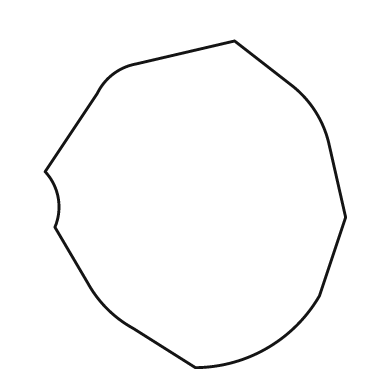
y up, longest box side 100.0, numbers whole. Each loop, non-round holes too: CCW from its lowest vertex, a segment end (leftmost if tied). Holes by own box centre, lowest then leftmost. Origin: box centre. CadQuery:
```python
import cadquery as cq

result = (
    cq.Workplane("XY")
    .moveTo(0.0, -50.0)
    .threePointArc((22.0, -44.0), (38.0, -28.0))
    .lineTo(46.0, -4.0)
    .lineTo(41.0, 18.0)
    .threePointArc((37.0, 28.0), (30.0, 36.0))
    .lineTo(12.0, 50.0)
    .lineTo(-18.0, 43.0)
    .threePointArc((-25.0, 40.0), (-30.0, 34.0))
    .lineTo(-46.0, 10.0)
    .threePointArc((-42.0, 2.0), (-43.0, -7.0))
    .lineTo(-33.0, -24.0)
    .threePointArc((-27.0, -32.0), (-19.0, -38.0))
    .close()
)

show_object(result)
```